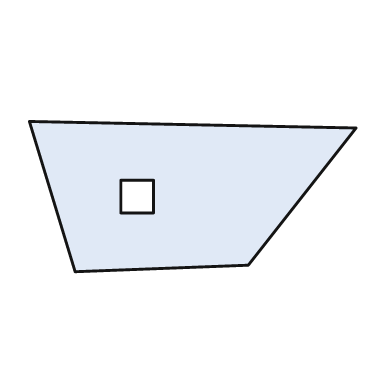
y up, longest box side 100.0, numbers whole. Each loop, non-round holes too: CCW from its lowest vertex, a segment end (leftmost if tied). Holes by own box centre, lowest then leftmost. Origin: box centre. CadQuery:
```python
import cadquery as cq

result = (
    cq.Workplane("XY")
    .moveTo(-36.0, -23.0)
    .lineTo(17.0, -21.0)
    .lineTo(50.0, 21.0)
    .lineTo(-50.0, 23.0)
    .close()
    .moveTo(-22.0, -5.0)
    .lineTo(-12.0, -5.0)
    .lineTo(-12.0, 5.0)
    .lineTo(-22.0, 5.0)
    .close()
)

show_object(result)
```